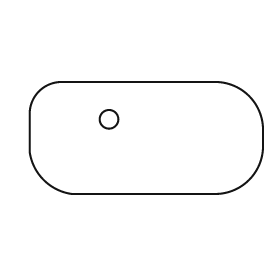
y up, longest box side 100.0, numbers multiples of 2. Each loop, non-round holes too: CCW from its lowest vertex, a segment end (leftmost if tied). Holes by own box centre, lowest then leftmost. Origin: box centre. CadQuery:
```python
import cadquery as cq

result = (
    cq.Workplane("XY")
    .moveTo(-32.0, -24.0)
    .lineTo(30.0, -24.0)
    .threePointArc((44.0, -18.0), (50.0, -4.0))
    .lineTo(50.0, 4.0)
    .threePointArc((44.0, 18.0), (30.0, 24.0))
    .lineTo(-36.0, 24.0)
    .threePointArc((-46.0, 20.0), (-50.0, 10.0))
    .lineTo(-50.0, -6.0)
    .threePointArc((-44.0, -18.0), (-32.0, -24.0))
    .close()
    .moveTo(-16.0, 8.0)
    .circle(4.0)
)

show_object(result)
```